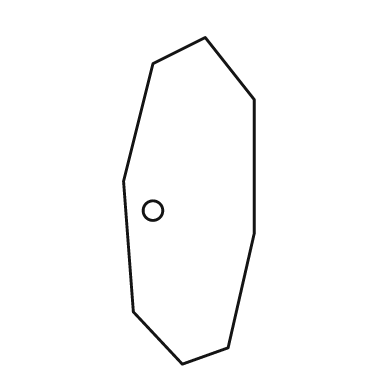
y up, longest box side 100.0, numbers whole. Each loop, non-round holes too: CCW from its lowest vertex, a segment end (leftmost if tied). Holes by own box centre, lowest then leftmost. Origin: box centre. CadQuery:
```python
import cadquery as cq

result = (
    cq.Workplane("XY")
    .moveTo(-2.0, -50.0)
    .lineTo(12.0, -45.0)
    .lineTo(20.0, -10.0)
    .lineTo(20.0, 31.0)
    .lineTo(5.0, 50.0)
    .lineTo(-11.0, 42.0)
    .lineTo(-20.0, 6.0)
    .lineTo(-17.0, -34.0)
    .close()
    .moveTo(-11.0, -3.0)
    .circle(3.0)
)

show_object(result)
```